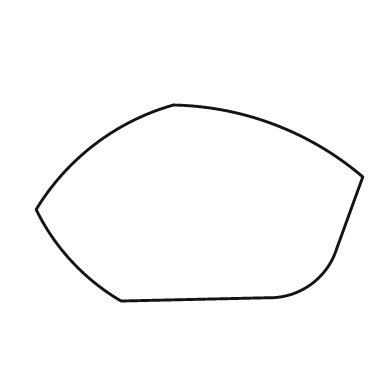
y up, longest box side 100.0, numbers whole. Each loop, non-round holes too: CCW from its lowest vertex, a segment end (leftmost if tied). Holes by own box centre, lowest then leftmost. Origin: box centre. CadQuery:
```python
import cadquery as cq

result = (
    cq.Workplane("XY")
    .moveTo(-24.0, -30.0)
    .lineTo(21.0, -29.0)
    .threePointArc((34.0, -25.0), (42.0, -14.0))
    .lineTo(50.0, 8.0)
    .threePointArc((23.0, 24.0), (-8.0, 30.0))
    .threePointArc((-32.0, 18.0), (-50.0, -2.0))
    .threePointArc((-39.0, -18.0), (-24.0, -30.0))
    .close()
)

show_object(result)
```